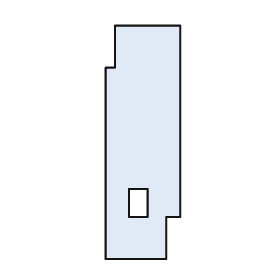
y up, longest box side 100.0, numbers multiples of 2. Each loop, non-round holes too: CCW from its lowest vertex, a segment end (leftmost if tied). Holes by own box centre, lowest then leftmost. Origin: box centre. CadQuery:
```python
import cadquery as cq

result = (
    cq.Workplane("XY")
    .moveTo(-16.0, -50.0)
    .lineTo(10.0, -50.0)
    .lineTo(10.0, -32.0)
    .lineTo(16.0, -32.0)
    .lineTo(16.0, 50.0)
    .lineTo(-12.0, 50.0)
    .lineTo(-12.0, 32.0)
    .lineTo(-16.0, 32.0)
    .close()
    .moveTo(-6.0, -32.0)
    .lineTo(2.0, -32.0)
    .lineTo(2.0, -20.0)
    .lineTo(-6.0, -20.0)
    .close()
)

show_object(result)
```